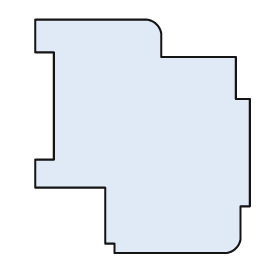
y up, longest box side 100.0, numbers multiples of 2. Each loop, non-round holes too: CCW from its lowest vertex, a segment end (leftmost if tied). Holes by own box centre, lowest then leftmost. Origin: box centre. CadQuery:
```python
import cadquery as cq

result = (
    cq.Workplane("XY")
    .moveTo(-12.0, -50.0)
    .lineTo(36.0, -50.0)
    .threePointArc((40.0, -48.0), (42.0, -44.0))
    .lineTo(42.0, -30.0)
    .lineTo(46.0, -30.0)
    .lineTo(46.0, 16.0)
    .lineTo(40.0, 16.0)
    .lineTo(40.0, 34.0)
    .lineTo(8.0, 34.0)
    .lineTo(8.0, 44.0)
    .threePointArc((6.0, 48.0), (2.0, 50.0))
    .lineTo(-46.0, 50.0)
    .lineTo(-46.0, 36.0)
    .lineTo(-38.0, 36.0)
    .lineTo(-38.0, -10.0)
    .lineTo(-46.0, -10.0)
    .lineTo(-46.0, -22.0)
    .lineTo(-16.0, -22.0)
    .lineTo(-16.0, -46.0)
    .lineTo(-12.0, -46.0)
    .close()
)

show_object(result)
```